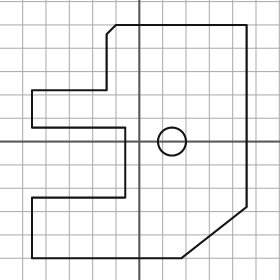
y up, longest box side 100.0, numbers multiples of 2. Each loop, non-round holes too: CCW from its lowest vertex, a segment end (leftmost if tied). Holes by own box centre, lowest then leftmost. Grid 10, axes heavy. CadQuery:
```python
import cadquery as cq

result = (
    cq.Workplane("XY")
    .moveTo(-46.0, -50.0)
    .lineTo(18.0, -50.0)
    .lineTo(46.0, -28.0)
    .lineTo(46.0, 50.0)
    .lineTo(-10.0, 50.0)
    .lineTo(-14.0, 46.0)
    .lineTo(-14.0, 22.0)
    .lineTo(-46.0, 22.0)
    .lineTo(-46.0, 6.0)
    .lineTo(-6.0, 6.0)
    .lineTo(-6.0, -24.0)
    .lineTo(-46.0, -24.0)
    .close()
    .moveTo(14.0, 0.0)
    .circle(6.0)
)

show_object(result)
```